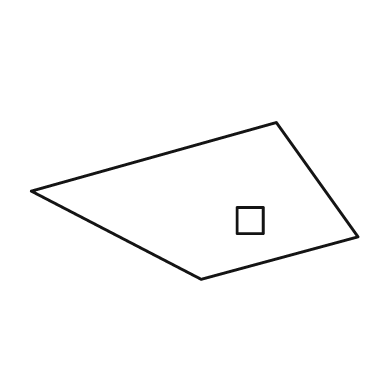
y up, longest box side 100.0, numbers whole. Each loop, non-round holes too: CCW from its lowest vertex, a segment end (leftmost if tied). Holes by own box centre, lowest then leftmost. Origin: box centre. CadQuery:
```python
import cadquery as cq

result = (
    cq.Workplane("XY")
    .moveTo(2.0, -24.0)
    .lineTo(50.0, -11.0)
    .lineTo(25.0, 24.0)
    .lineTo(-50.0, 3.0)
    .close()
    .moveTo(13.0, -10.0)
    .lineTo(21.0, -10.0)
    .lineTo(21.0, -2.0)
    .lineTo(13.0, -2.0)
    .close()
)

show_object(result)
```